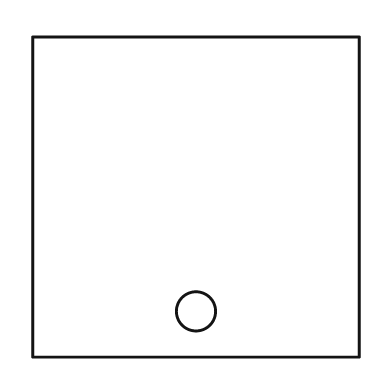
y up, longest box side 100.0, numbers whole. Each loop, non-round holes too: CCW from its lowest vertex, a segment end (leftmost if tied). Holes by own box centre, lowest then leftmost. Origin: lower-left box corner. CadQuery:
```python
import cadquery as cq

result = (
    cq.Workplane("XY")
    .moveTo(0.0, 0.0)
    .lineTo(100.0, 0.0)
    .lineTo(100.0, 98.0)
    .lineTo(0.0, 98.0)
    .close()
    .moveTo(50.0, 14.0)
    .circle(6.0)
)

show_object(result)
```